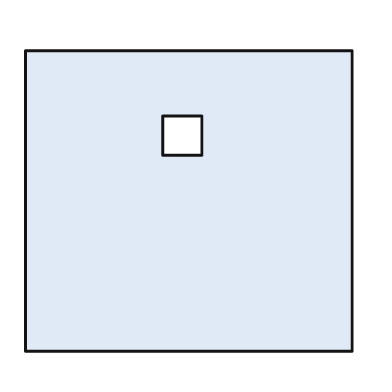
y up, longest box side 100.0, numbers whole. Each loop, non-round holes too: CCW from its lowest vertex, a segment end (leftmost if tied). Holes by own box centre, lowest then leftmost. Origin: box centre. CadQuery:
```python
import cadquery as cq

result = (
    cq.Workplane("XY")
    .moveTo(-50.0, -46.0)
    .lineTo(50.0, -46.0)
    .lineTo(50.0, 46.0)
    .lineTo(-50.0, 46.0)
    .close()
    .moveTo(-8.0, 14.0)
    .lineTo(4.0, 14.0)
    .lineTo(4.0, 26.0)
    .lineTo(-8.0, 26.0)
    .close()
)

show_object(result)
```